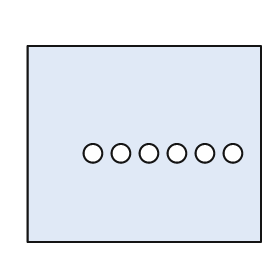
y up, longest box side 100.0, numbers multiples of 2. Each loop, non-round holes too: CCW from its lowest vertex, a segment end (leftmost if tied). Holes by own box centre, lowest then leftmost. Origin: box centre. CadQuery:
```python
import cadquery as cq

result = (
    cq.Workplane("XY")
    .moveTo(-50.0, -42.0)
    .lineTo(50.0, -42.0)
    .lineTo(50.0, 42.0)
    .lineTo(-50.0, 42.0)
    .close()
    .moveTo(-22.0, -4.0)
    .circle(4.0)
    .moveTo(-10.0, -4.0)
    .circle(4.0)
    .moveTo(2.0, -4.0)
    .circle(4.0)
    .moveTo(14.0, -4.0)
    .circle(4.0)
    .moveTo(26.0, -4.0)
    .circle(4.0)
    .moveTo(38.0, -4.0)
    .circle(4.0)
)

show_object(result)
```